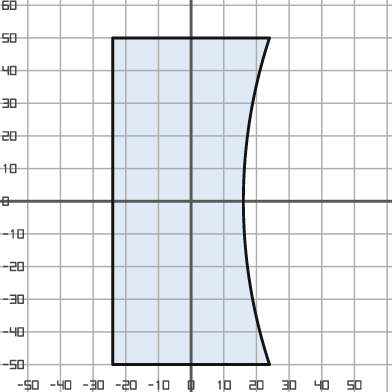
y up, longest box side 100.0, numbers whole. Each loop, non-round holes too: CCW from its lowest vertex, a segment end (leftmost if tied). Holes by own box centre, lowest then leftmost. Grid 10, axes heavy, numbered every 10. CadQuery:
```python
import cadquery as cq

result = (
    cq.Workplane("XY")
    .moveTo(-24.0, -50.0)
    .lineTo(24.0, -50.0)
    .threePointArc((16.0, 0.0), (24.0, 50.0))
    .lineTo(-24.0, 50.0)
    .close()
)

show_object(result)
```